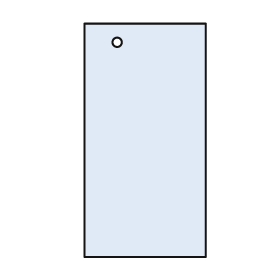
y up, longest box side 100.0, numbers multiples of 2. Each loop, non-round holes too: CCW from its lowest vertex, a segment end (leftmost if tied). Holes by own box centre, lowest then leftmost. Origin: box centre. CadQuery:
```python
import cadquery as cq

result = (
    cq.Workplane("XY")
    .moveTo(-26.0, -50.0)
    .lineTo(26.0, -50.0)
    .lineTo(26.0, 50.0)
    .lineTo(-26.0, 50.0)
    .close()
    .moveTo(-12.0, 42.0)
    .circle(2.0)
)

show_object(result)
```